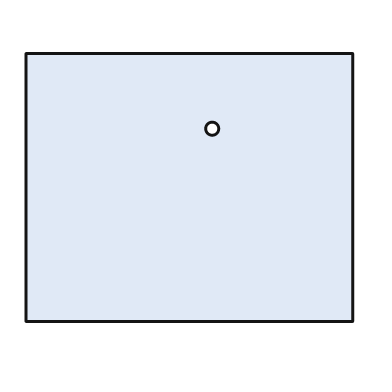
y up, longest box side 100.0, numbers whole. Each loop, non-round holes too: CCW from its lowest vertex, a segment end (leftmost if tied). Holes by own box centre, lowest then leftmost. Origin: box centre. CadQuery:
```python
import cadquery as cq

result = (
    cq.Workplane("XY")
    .moveTo(-50.0, -41.0)
    .lineTo(50.0, -41.0)
    .lineTo(50.0, 41.0)
    .lineTo(-50.0, 41.0)
    .close()
    .moveTo(7.0, 18.0)
    .circle(2.0)
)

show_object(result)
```